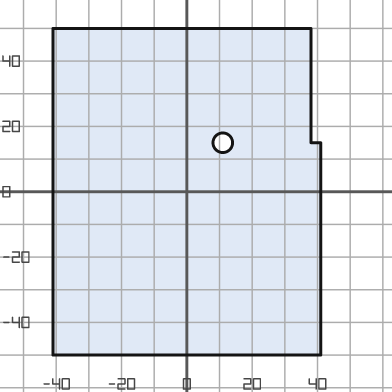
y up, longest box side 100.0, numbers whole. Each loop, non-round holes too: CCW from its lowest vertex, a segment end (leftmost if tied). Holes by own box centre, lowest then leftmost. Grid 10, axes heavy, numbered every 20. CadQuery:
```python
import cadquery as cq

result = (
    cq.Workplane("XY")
    .moveTo(-41.0, -50.0)
    .lineTo(41.0, -50.0)
    .lineTo(41.0, 15.0)
    .lineTo(38.0, 15.0)
    .lineTo(38.0, 50.0)
    .lineTo(-41.0, 50.0)
    .close()
    .moveTo(11.0, 15.0)
    .circle(3.0)
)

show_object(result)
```